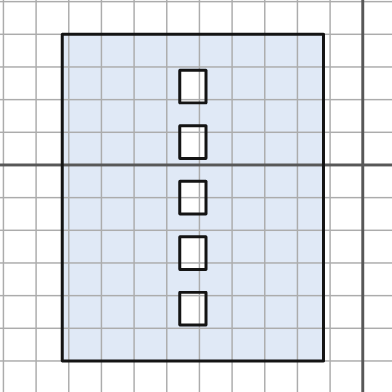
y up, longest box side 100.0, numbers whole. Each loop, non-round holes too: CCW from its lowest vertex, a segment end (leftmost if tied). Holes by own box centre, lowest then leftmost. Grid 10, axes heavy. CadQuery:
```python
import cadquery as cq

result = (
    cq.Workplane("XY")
    .moveTo(-92.0, -60.0)
    .lineTo(-12.0, -60.0)
    .lineTo(-12.0, 40.0)
    .lineTo(-92.0, 40.0)
    .close()
    .moveTo(-56.0, -49.0)
    .lineTo(-48.0, -49.0)
    .lineTo(-48.0, -39.0)
    .lineTo(-56.0, -39.0)
    .close()
    .moveTo(-56.0, -32.0)
    .lineTo(-48.0, -32.0)
    .lineTo(-48.0, -22.0)
    .lineTo(-56.0, -22.0)
    .close()
    .moveTo(-56.0, -15.0)
    .lineTo(-48.0, -15.0)
    .lineTo(-48.0, -5.0)
    .lineTo(-56.0, -5.0)
    .close()
    .moveTo(-56.0, 2.0)
    .lineTo(-48.0, 2.0)
    .lineTo(-48.0, 12.0)
    .lineTo(-56.0, 12.0)
    .close()
    .moveTo(-56.0, 19.0)
    .lineTo(-48.0, 19.0)
    .lineTo(-48.0, 29.0)
    .lineTo(-56.0, 29.0)
    .close()
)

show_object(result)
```